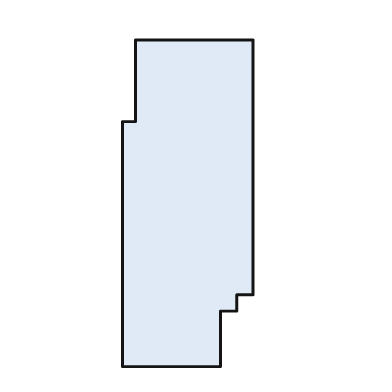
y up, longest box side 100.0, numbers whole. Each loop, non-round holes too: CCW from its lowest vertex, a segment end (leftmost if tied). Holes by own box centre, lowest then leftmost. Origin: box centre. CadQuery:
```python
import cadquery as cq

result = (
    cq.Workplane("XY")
    .moveTo(-20.0, -50.0)
    .lineTo(10.0, -50.0)
    .lineTo(10.0, -33.0)
    .lineTo(15.0, -33.0)
    .lineTo(15.0, -28.0)
    .lineTo(20.0, -28.0)
    .lineTo(20.0, 50.0)
    .lineTo(-16.0, 50.0)
    .lineTo(-16.0, 25.0)
    .lineTo(-20.0, 25.0)
    .close()
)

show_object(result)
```